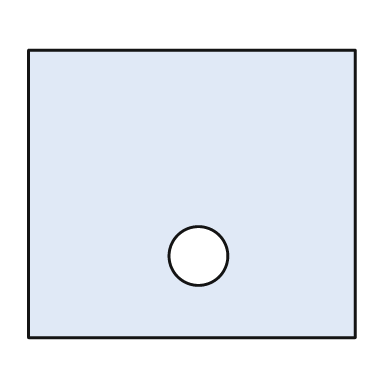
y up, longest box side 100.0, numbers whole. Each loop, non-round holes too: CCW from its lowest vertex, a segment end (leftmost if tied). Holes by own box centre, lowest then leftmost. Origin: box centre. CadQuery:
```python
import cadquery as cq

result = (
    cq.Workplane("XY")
    .moveTo(-50.0, -44.0)
    .lineTo(50.0, -44.0)
    .lineTo(50.0, 44.0)
    .lineTo(-50.0, 44.0)
    .close()
    .moveTo(2.0, -19.0)
    .circle(9.0)
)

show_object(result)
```